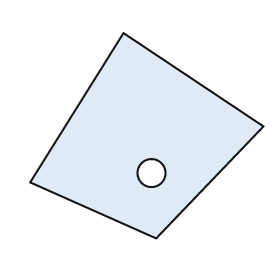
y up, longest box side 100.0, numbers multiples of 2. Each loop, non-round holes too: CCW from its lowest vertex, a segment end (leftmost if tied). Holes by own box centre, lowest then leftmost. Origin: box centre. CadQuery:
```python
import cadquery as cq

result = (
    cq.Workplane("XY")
    .moveTo(4.0, -44.0)
    .lineTo(50.0, 4.0)
    .lineTo(-10.0, 44.0)
    .lineTo(-50.0, -20.0)
    .close()
    .moveTo(2.0, -16.0)
    .circle(6.0)
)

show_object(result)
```